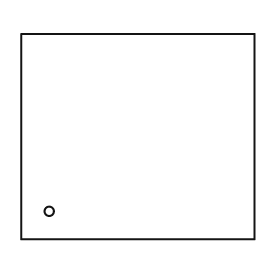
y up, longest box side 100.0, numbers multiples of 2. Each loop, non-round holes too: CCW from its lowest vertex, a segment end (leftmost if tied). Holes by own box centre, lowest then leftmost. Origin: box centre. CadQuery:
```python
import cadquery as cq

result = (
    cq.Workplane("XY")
    .moveTo(-50.0, -44.0)
    .lineTo(50.0, -44.0)
    .lineTo(50.0, 44.0)
    .lineTo(-50.0, 44.0)
    .close()
    .moveTo(-38.0, -32.0)
    .circle(2.0)
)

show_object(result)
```